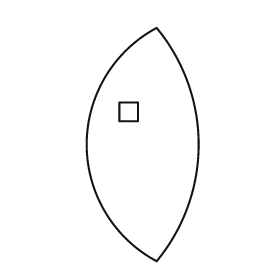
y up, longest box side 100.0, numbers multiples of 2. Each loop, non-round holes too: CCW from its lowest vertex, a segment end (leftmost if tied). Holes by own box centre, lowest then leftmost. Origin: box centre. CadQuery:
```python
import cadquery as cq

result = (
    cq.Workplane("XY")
    .moveTo(6.0, -50.0)
    .threePointArc((24.0, 0.0), (6.0, 50.0))
    .threePointArc((-24.0, 0.0), (6.0, -50.0))
    .close()
    .moveTo(-10.0, 10.0)
    .lineTo(-2.0, 10.0)
    .lineTo(-2.0, 18.0)
    .lineTo(-10.0, 18.0)
    .close()
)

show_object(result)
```